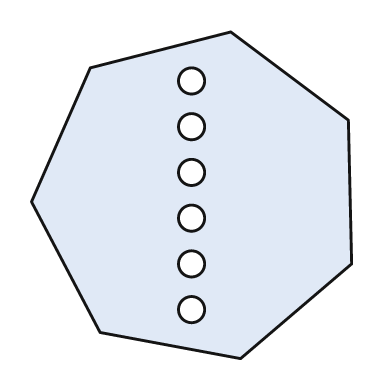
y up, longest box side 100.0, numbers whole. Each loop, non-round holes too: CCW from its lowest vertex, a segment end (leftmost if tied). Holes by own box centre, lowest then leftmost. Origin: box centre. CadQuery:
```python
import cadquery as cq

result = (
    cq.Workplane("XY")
    .moveTo(15.0, -50.0)
    .lineTo(49.0, -21.0)
    .lineTo(48.0, 23.0)
    .lineTo(12.0, 50.0)
    .lineTo(-31.0, 39.0)
    .lineTo(-49.0, -2.0)
    .lineTo(-28.0, -42.0)
    .close()
    .moveTo(0.0, -35.0)
    .circle(4.0)
    .moveTo(0.0, -21.0)
    .circle(4.0)
    .moveTo(0.0, -7.0)
    .circle(4.0)
    .moveTo(0.0, 7.0)
    .circle(4.0)
    .moveTo(0.0, 21.0)
    .circle(4.0)
    .moveTo(0.0, 35.0)
    .circle(4.0)
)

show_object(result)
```